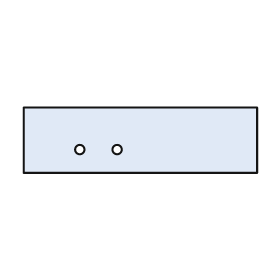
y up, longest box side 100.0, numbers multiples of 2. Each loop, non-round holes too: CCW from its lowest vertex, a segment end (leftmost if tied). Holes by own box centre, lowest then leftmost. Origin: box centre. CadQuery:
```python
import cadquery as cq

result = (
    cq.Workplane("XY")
    .moveTo(-50.0, -14.0)
    .lineTo(50.0, -14.0)
    .lineTo(50.0, 14.0)
    .lineTo(-50.0, 14.0)
    .close()
    .moveTo(-26.0, -4.0)
    .circle(2.0)
    .moveTo(-10.0, -4.0)
    .circle(2.0)
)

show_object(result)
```